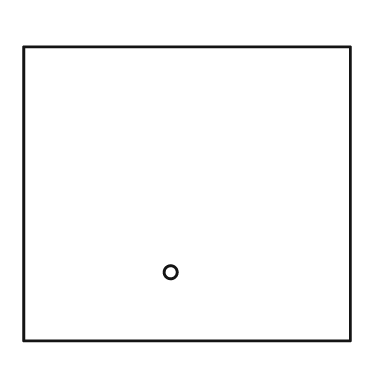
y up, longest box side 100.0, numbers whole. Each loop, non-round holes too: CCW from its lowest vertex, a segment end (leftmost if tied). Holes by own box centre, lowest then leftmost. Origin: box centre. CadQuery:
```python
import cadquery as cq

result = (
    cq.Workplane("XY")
    .moveTo(-50.0, -45.0)
    .lineTo(50.0, -45.0)
    .lineTo(50.0, 45.0)
    .lineTo(-50.0, 45.0)
    .close()
    .moveTo(-5.0, -24.0)
    .circle(2.0)
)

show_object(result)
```